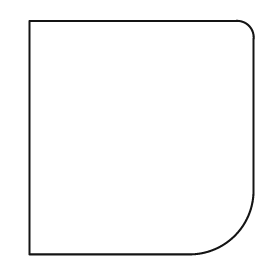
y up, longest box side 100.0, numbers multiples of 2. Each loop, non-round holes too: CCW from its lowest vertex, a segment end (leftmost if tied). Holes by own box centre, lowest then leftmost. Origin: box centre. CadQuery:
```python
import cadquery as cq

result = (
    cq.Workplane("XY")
    .moveTo(-48.0, -50.0)
    .lineTo(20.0, -50.0)
    .threePointArc((40.0, -42.0), (48.0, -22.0))
    .lineTo(48.0, 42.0)
    .threePointArc((46.0, 48.0), (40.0, 50.0))
    .lineTo(-48.0, 50.0)
    .close()
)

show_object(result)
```